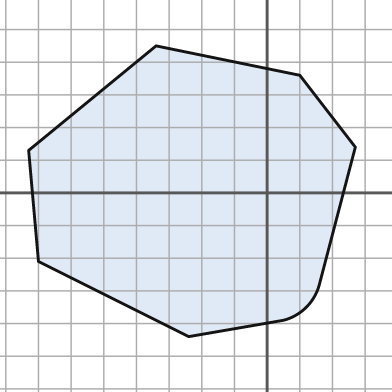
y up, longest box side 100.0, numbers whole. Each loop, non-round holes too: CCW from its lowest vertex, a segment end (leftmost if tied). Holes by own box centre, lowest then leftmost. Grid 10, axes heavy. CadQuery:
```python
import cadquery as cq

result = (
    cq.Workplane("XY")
    .moveTo(-24.0, -44.0)
    .lineTo(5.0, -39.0)
    .threePointArc((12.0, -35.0), (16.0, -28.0))
    .lineTo(27.0, 14.0)
    .lineTo(10.0, 36.0)
    .lineTo(-34.0, 45.0)
    .lineTo(-73.0, 13.0)
    .lineTo(-70.0, -21.0)
    .close()
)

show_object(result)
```